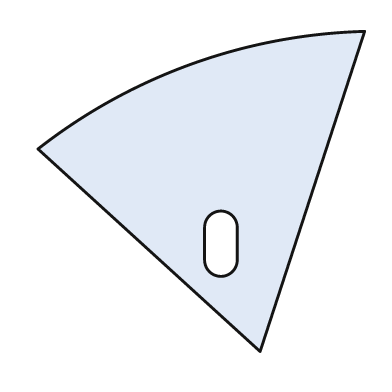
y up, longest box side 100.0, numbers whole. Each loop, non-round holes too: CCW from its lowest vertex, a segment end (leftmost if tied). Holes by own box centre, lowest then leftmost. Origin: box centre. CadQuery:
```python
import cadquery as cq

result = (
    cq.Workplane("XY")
    .moveTo(18.0, -49.0)
    .lineTo(50.0, 49.0)
    .threePointArc((-3.0, 39.0), (-50.0, 13.0))
    .close()
    .moveTo(1.0, -21.0)
    .threePointArc((6.0, -26.0), (11.0, -21.0))
    .lineTo(11.0, -11.0)
    .threePointArc((6.0, -6.0), (1.0, -11.0))
    .close()
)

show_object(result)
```